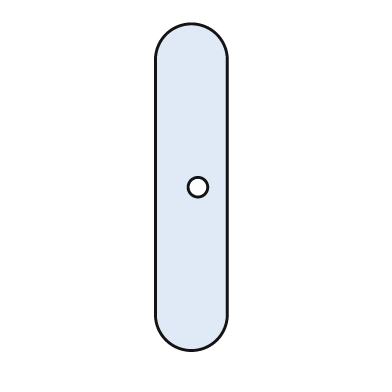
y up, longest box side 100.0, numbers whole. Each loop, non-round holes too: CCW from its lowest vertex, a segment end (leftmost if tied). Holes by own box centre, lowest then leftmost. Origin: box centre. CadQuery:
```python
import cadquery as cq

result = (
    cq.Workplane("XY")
    .moveTo(-11.0, -39.0)
    .threePointArc((0.0, -50.0), (11.0, -39.0))
    .lineTo(11.0, 39.0)
    .threePointArc((0.0, 50.0), (-11.0, 39.0))
    .close()
    .moveTo(2.0, 0.0)
    .circle(3.0)
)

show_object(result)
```